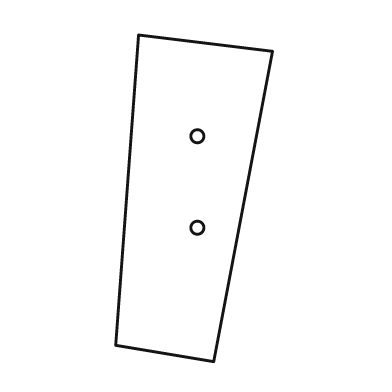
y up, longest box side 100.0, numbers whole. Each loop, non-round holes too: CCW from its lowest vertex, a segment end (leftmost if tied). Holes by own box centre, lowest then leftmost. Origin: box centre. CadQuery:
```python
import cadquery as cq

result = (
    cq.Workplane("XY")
    .moveTo(6.0, -50.0)
    .lineTo(24.0, 45.0)
    .lineTo(-17.0, 50.0)
    .lineTo(-24.0, -45.0)
    .close()
    .moveTo(1.0, -9.0)
    .circle(2.0)
    .moveTo(1.0, 19.0)
    .circle(2.0)
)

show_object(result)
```